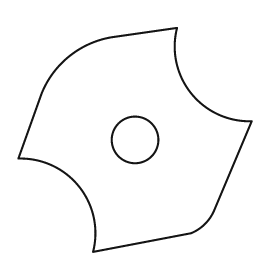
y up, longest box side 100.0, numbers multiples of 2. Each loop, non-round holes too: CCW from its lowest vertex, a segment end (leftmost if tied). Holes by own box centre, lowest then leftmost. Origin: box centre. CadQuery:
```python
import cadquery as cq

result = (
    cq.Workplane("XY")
    .moveTo(-18.0, -48.0)
    .lineTo(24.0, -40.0)
    .threePointArc((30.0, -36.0), (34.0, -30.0))
    .lineTo(50.0, 8.0)
    .threePointArc((24.0, 20.0), (18.0, 48.0))
    .lineTo(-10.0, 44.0)
    .threePointArc((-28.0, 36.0), (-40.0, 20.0))
    .lineTo(-50.0, -8.0)
    .threePointArc((-24.0, -20.0), (-18.0, -48.0))
    .close()
    .moveTo(0.0, 0.0)
    .circle(10.0)
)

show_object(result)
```